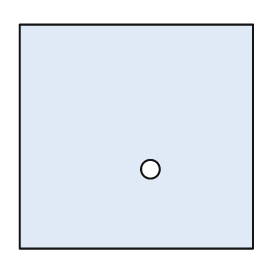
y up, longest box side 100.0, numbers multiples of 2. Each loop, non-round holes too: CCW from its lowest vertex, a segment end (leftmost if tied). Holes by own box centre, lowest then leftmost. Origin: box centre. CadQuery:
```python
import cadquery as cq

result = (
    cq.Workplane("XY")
    .moveTo(-50.0, -48.0)
    .lineTo(50.0, -48.0)
    .lineTo(50.0, 48.0)
    .lineTo(-50.0, 48.0)
    .close()
    .moveTo(6.0, -14.0)
    .circle(4.0)
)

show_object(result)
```